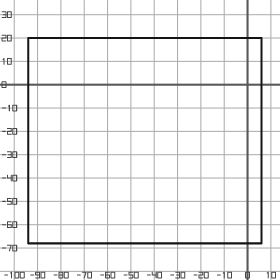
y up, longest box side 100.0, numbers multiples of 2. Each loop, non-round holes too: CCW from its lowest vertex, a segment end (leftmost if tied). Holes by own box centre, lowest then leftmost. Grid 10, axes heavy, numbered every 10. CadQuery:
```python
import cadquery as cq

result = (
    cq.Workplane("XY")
    .moveTo(-94.0, -68.0)
    .lineTo(6.0, -68.0)
    .lineTo(6.0, 20.0)
    .lineTo(-94.0, 20.0)
    .close()
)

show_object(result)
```